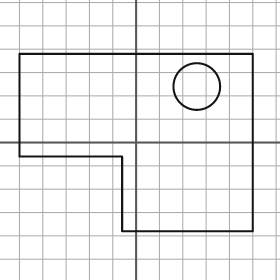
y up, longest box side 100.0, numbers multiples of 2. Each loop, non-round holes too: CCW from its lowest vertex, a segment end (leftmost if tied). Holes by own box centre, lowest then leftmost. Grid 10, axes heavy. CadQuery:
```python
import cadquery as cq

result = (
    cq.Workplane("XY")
    .moveTo(-6.0, -38.0)
    .lineTo(50.0, -38.0)
    .lineTo(50.0, 38.0)
    .lineTo(-50.0, 38.0)
    .lineTo(-50.0, -6.0)
    .lineTo(-6.0, -6.0)
    .close()
    .moveTo(26.0, 24.0)
    .circle(10.0)
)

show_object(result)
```